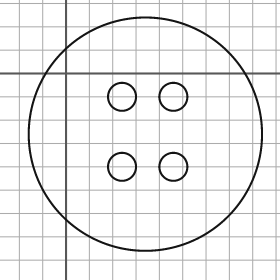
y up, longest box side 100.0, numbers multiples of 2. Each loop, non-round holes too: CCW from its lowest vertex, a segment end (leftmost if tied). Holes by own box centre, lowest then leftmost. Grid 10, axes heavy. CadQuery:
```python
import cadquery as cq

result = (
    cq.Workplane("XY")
    .moveTo(34.0, -26.0)
    .circle(50.0)
    .moveTo(24.0, -40.0)
    .circle(6.0)
    .moveTo(46.0, -40.0)
    .circle(6.0)
    .moveTo(24.0, -10.0)
    .circle(6.0)
    .moveTo(46.0, -10.0)
    .circle(6.0)
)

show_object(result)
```